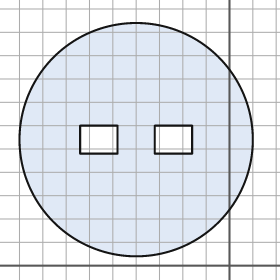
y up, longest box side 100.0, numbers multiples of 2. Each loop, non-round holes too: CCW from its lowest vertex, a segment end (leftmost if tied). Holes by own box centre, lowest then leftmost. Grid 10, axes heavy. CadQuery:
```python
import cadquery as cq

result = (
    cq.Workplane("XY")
    .moveTo(-40.0, 54.0)
    .circle(50.0)
    .moveTo(-64.0, 48.0)
    .lineTo(-48.0, 48.0)
    .lineTo(-48.0, 60.0)
    .lineTo(-64.0, 60.0)
    .close()
    .moveTo(-32.0, 48.0)
    .lineTo(-16.0, 48.0)
    .lineTo(-16.0, 60.0)
    .lineTo(-32.0, 60.0)
    .close()
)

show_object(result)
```